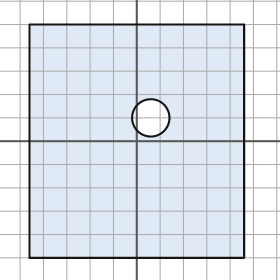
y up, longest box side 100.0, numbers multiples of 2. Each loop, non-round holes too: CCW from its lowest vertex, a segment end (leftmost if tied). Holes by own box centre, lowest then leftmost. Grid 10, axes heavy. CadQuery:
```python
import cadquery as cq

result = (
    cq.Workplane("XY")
    .moveTo(-46.0, -50.0)
    .lineTo(46.0, -50.0)
    .lineTo(46.0, 50.0)
    .lineTo(-46.0, 50.0)
    .close()
    .moveTo(6.0, 10.0)
    .circle(8.0)
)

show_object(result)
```